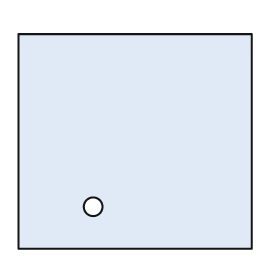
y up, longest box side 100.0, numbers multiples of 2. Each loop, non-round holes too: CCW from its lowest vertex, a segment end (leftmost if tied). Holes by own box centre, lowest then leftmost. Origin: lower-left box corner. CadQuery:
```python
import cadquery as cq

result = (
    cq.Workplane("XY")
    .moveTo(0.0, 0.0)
    .lineTo(100.0, 0.0)
    .lineTo(100.0, 92.0)
    .lineTo(0.0, 92.0)
    .close()
    .moveTo(32.0, 18.0)
    .circle(4.0)
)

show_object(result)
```